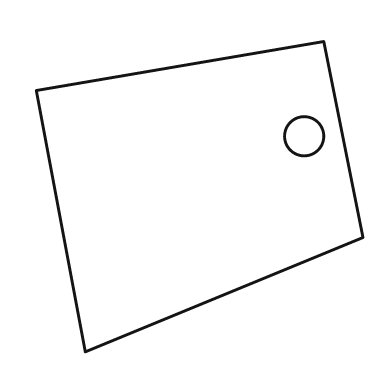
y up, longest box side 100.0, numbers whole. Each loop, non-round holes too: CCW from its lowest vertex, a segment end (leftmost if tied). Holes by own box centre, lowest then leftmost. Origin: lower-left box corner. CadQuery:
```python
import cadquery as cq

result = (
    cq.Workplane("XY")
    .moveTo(15.0, 0.0)
    .lineTo(100.0, 35.0)
    .lineTo(88.0, 95.0)
    .lineTo(0.0, 80.0)
    .close()
    .moveTo(82.0, 66.0)
    .circle(6.0)
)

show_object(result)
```